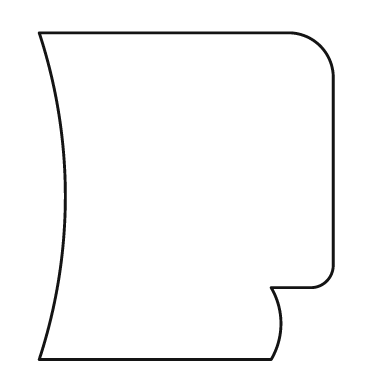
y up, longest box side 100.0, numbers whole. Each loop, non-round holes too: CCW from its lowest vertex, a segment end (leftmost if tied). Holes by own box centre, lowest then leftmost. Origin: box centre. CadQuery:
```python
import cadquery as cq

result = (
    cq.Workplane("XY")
    .moveTo(-45.0, -50.0)
    .lineTo(26.0, -50.0)
    .threePointArc((29.0, -39.0), (26.0, -28.0))
    .lineTo(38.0, -28.0)
    .threePointArc((43.0, -26.0), (45.0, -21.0))
    .lineTo(45.0, 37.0)
    .threePointArc((41.0, 46.0), (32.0, 50.0))
    .lineTo(-45.0, 50.0)
    .threePointArc((-37.0, 0.0), (-45.0, -50.0))
    .close()
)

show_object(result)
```